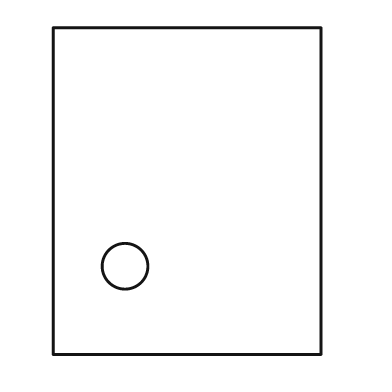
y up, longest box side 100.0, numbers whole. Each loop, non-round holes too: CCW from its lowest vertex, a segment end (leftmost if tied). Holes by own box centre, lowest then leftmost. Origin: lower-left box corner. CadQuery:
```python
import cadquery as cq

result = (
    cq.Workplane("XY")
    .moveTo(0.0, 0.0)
    .lineTo(82.0, 0.0)
    .lineTo(82.0, 100.0)
    .lineTo(0.0, 100.0)
    .close()
    .moveTo(22.0, 27.0)
    .circle(7.0)
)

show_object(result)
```